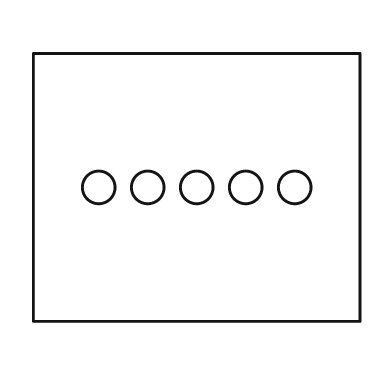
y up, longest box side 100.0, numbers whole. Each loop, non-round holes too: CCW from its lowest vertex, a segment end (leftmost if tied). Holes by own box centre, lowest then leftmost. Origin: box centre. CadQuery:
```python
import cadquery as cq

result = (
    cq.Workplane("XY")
    .moveTo(-50.0, -41.0)
    .lineTo(50.0, -41.0)
    .lineTo(50.0, 41.0)
    .lineTo(-50.0, 41.0)
    .close()
    .moveTo(-30.0, 0.0)
    .circle(5.0)
    .moveTo(-15.0, 0.0)
    .circle(5.0)
    .moveTo(0.0, 0.0)
    .circle(5.0)
    .moveTo(15.0, 0.0)
    .circle(5.0)
    .moveTo(30.0, 0.0)
    .circle(5.0)
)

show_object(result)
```